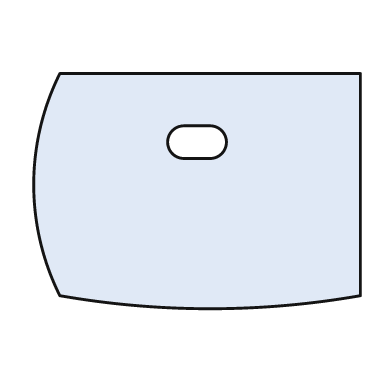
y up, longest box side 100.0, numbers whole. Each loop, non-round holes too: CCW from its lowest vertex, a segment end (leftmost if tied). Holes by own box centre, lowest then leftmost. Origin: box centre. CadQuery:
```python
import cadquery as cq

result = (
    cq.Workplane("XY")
    .moveTo(-42.0, -32.0)
    .threePointArc((4.0, -36.0), (50.0, -32.0))
    .lineTo(50.0, 36.0)
    .lineTo(-42.0, 36.0)
    .threePointArc((-50.0, 2.0), (-42.0, -32.0))
    .close()
    .moveTo(-4.0, 10.0)
    .lineTo(4.0, 10.0)
    .threePointArc((9.0, 15.0), (4.0, 20.0))
    .lineTo(-4.0, 20.0)
    .threePointArc((-9.0, 15.0), (-4.0, 10.0))
    .close()
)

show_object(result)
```